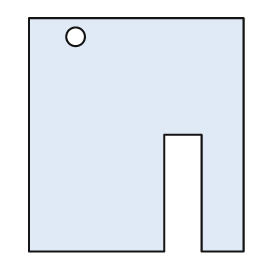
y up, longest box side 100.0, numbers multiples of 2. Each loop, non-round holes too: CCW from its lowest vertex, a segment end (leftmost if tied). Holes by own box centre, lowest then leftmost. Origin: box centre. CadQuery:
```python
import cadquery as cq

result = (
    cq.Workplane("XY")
    .moveTo(-46.0, -50.0)
    .lineTo(12.0, -50.0)
    .lineTo(12.0, 0.0)
    .lineTo(28.0, 0.0)
    .lineTo(28.0, -50.0)
    .lineTo(46.0, -50.0)
    .lineTo(46.0, 50.0)
    .lineTo(-46.0, 50.0)
    .close()
    .moveTo(-26.0, 42.0)
    .circle(4.0)
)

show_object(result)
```